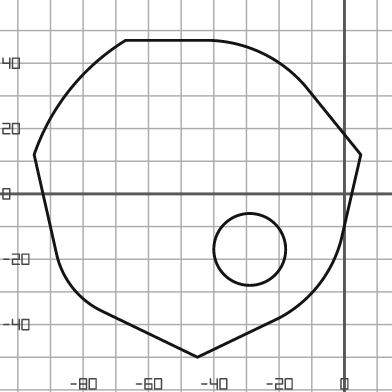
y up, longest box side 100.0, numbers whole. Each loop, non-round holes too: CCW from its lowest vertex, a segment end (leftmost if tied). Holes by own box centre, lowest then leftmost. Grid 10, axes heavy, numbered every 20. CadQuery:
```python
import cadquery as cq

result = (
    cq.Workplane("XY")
    .moveTo(-45.0, -50.0)
    .lineTo(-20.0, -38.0)
    .threePointArc((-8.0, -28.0), (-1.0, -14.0))
    .lineTo(5.0, 12.0)
    .lineTo(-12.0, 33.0)
    .threePointArc((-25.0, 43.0), (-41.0, 47.0))
    .lineTo(-67.0, 47.0)
    .threePointArc((-84.0, 32.0), (-95.0, 12.0))
    .lineTo(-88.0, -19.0)
    .threePointArc((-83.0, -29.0), (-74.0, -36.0))
    .close()
    .moveTo(-29.0, -17.0)
    .circle(11.0)
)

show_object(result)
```